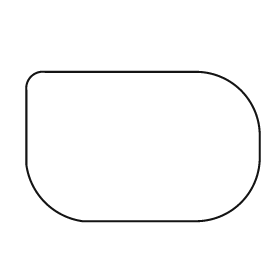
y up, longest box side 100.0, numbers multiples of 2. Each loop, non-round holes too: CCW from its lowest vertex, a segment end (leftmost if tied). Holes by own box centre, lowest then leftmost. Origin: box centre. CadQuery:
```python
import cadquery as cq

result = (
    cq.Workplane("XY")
    .moveTo(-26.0, -32.0)
    .lineTo(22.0, -32.0)
    .threePointArc((42.0, -24.0), (50.0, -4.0))
    .lineTo(50.0, 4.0)
    .threePointArc((42.0, 24.0), (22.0, 32.0))
    .lineTo(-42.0, 32.0)
    .threePointArc((-48.0, 30.0), (-50.0, 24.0))
    .lineTo(-50.0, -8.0)
    .threePointArc((-42.0, -24.0), (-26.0, -32.0))
    .close()
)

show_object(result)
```